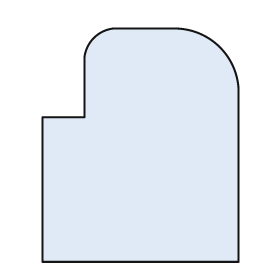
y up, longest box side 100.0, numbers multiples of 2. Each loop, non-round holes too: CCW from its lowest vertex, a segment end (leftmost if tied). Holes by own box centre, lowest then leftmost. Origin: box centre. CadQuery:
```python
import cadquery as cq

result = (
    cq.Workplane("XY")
    .moveTo(-42.0, -50.0)
    .lineTo(42.0, -50.0)
    .lineTo(42.0, 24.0)
    .threePointArc((34.0, 42.0), (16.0, 50.0))
    .lineTo(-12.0, 50.0)
    .threePointArc((-20.0, 46.0), (-24.0, 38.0))
    .lineTo(-24.0, 12.0)
    .lineTo(-42.0, 12.0)
    .close()
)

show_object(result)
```